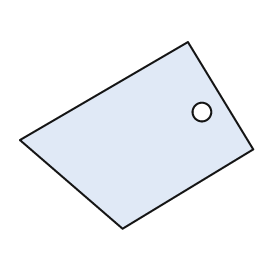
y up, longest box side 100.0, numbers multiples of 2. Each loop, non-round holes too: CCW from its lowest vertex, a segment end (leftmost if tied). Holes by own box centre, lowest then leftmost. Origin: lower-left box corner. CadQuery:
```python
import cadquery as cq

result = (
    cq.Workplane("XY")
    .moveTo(44.0, 0.0)
    .lineTo(100.0, 34.0)
    .lineTo(72.0, 80.0)
    .lineTo(0.0, 38.0)
    .close()
    .moveTo(78.0, 50.0)
    .circle(4.0)
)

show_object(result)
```